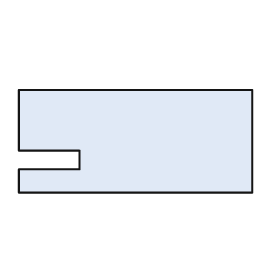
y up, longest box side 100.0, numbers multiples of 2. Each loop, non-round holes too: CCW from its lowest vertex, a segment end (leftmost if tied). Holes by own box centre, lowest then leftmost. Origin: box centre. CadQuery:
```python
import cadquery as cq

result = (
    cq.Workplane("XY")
    .moveTo(-50.0, -22.0)
    .lineTo(50.0, -22.0)
    .lineTo(50.0, 22.0)
    .lineTo(-50.0, 22.0)
    .lineTo(-50.0, -4.0)
    .lineTo(-24.0, -4.0)
    .lineTo(-24.0, -12.0)
    .lineTo(-50.0, -12.0)
    .close()
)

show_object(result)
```